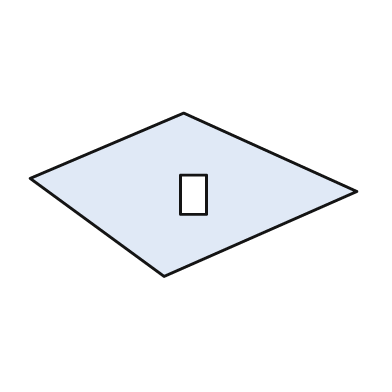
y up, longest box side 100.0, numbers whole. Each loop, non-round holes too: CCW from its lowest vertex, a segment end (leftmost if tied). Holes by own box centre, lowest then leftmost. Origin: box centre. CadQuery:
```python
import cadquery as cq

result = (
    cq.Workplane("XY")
    .moveTo(-9.0, -25.0)
    .lineTo(50.0, 1.0)
    .lineTo(-3.0, 25.0)
    .lineTo(-50.0, 5.0)
    .close()
    .moveTo(-4.0, -6.0)
    .lineTo(4.0, -6.0)
    .lineTo(4.0, 6.0)
    .lineTo(-4.0, 6.0)
    .close()
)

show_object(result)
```